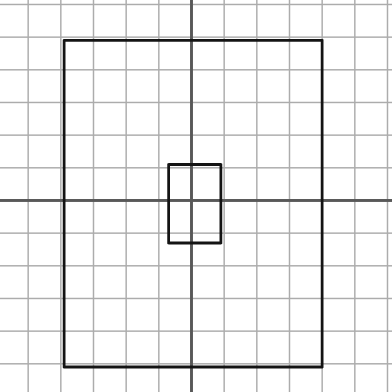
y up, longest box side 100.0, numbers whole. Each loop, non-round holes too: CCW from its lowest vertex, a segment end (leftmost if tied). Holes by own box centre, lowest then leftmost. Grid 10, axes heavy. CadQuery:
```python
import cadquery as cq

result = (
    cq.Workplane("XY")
    .moveTo(-39.0, -51.0)
    .lineTo(40.0, -51.0)
    .lineTo(40.0, 49.0)
    .lineTo(-39.0, 49.0)
    .close()
    .moveTo(-7.0, -13.0)
    .lineTo(9.0, -13.0)
    .lineTo(9.0, 11.0)
    .lineTo(-7.0, 11.0)
    .close()
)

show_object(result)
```